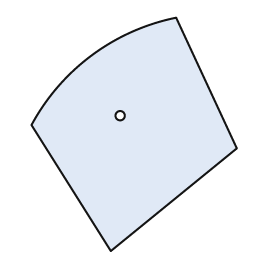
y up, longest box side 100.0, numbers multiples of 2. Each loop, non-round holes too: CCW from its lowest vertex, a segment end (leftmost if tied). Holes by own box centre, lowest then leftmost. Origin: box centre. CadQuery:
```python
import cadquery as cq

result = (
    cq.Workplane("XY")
    .moveTo(-10.0, -50.0)
    .lineTo(44.0, -6.0)
    .lineTo(18.0, 50.0)
    .threePointArc((-18.0, 34.0), (-44.0, 4.0))
    .close()
    .moveTo(-6.0, 8.0)
    .circle(2.0)
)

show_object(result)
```